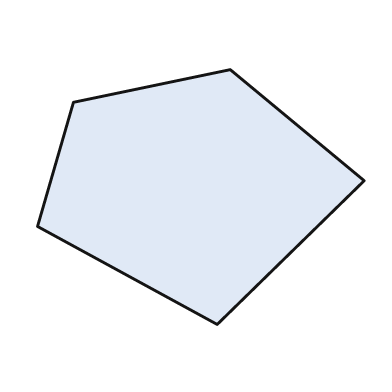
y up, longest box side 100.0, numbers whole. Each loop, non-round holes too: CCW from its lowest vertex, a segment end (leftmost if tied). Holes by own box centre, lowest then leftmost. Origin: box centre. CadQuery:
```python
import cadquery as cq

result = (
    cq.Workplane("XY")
    .moveTo(5.0, -39.0)
    .lineTo(50.0, 5.0)
    .lineTo(9.0, 39.0)
    .lineTo(-39.0, 29.0)
    .lineTo(-50.0, -9.0)
    .close()
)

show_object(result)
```